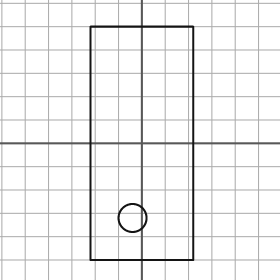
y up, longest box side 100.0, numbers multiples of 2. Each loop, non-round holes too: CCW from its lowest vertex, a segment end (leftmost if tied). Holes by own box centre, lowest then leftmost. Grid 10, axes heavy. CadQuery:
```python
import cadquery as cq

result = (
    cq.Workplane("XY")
    .moveTo(-22.0, -50.0)
    .lineTo(22.0, -50.0)
    .lineTo(22.0, 50.0)
    .lineTo(-22.0, 50.0)
    .close()
    .moveTo(-4.0, -32.0)
    .circle(6.0)
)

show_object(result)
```